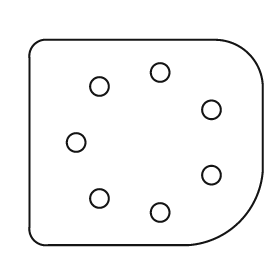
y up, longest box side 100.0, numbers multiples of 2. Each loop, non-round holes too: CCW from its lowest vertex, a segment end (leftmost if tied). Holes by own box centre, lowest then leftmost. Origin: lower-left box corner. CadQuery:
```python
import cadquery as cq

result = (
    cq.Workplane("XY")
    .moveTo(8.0, 0.0)
    .lineTo(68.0, 0.0)
    .threePointArc((90.0, 10.0), (100.0, 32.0))
    .lineTo(100.0, 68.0)
    .threePointArc((94.0, 82.0), (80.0, 88.0))
    .lineTo(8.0, 88.0)
    .threePointArc((2.0, 86.0), (0.0, 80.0))
    .lineTo(0.0, 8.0)
    .threePointArc((2.0, 2.0), (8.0, 0.0))
    .close()
    .moveTo(56.0, 14.0)
    .circle(4.0)
    .moveTo(30.0, 20.0)
    .circle(4.0)
    .moveTo(78.0, 30.0)
    .circle(4.0)
    .moveTo(20.0, 44.0)
    .circle(4.0)
    .moveTo(78.0, 58.0)
    .circle(4.0)
    .moveTo(30.0, 68.0)
    .circle(4.0)
    .moveTo(56.0, 74.0)
    .circle(4.0)
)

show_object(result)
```